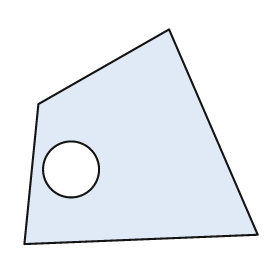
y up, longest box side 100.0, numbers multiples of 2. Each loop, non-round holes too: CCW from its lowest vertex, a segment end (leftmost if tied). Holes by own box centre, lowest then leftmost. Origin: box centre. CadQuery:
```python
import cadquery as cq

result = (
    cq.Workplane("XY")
    .moveTo(-50.0, -46.0)
    .lineTo(50.0, -42.0)
    .lineTo(12.0, 46.0)
    .lineTo(-44.0, 14.0)
    .close()
    .moveTo(-30.0, -14.0)
    .circle(12.0)
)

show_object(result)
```